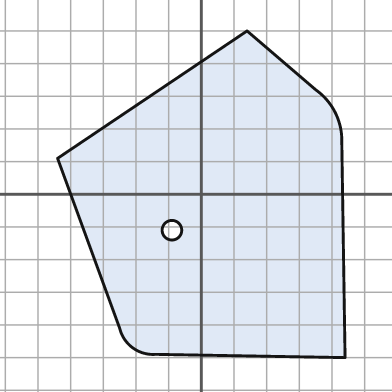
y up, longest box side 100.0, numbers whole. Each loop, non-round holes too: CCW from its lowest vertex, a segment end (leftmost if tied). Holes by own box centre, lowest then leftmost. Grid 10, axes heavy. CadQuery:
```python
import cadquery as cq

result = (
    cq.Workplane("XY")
    .moveTo(44.0, -50.0)
    .lineTo(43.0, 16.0)
    .threePointArc((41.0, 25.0), (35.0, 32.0))
    .lineTo(14.0, 50.0)
    .lineTo(-44.0, 11.0)
    .lineTo(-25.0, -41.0)
    .threePointArc((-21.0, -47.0), (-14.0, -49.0))
    .close()
    .moveTo(-9.0, -11.0)
    .circle(3.0)
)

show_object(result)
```